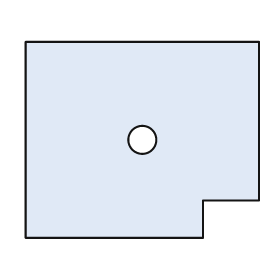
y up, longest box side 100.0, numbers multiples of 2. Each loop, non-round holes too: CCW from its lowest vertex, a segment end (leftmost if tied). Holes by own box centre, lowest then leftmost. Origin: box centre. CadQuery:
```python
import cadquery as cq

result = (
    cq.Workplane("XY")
    .moveTo(-50.0, -42.0)
    .lineTo(26.0, -42.0)
    .lineTo(26.0, -26.0)
    .lineTo(50.0, -26.0)
    .lineTo(50.0, 42.0)
    .lineTo(-50.0, 42.0)
    .close()
    .moveTo(0.0, 0.0)
    .circle(6.0)
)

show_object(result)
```